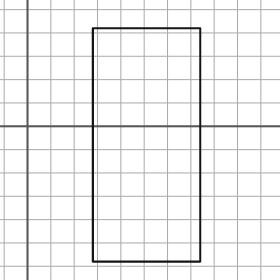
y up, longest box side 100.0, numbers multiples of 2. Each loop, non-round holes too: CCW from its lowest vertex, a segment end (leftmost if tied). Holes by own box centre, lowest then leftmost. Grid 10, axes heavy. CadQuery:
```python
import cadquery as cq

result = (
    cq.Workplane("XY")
    .moveTo(28.0, -58.0)
    .lineTo(74.0, -58.0)
    .lineTo(74.0, 42.0)
    .lineTo(28.0, 42.0)
    .close()
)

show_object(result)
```